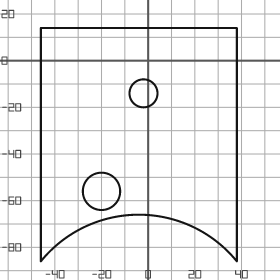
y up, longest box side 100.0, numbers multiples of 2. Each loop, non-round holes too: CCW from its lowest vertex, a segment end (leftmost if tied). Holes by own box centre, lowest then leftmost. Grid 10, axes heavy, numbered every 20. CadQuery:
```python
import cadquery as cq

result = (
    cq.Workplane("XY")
    .moveTo(-46.0, -86.0)
    .threePointArc((-4.0, -66.0), (38.0, -86.0))
    .lineTo(38.0, 14.0)
    .lineTo(-46.0, 14.0)
    .close()
    .moveTo(-20.0, -56.0)
    .circle(8.0)
    .moveTo(-2.0, -14.0)
    .circle(6.0)
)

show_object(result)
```